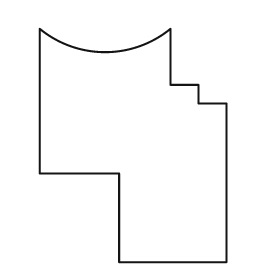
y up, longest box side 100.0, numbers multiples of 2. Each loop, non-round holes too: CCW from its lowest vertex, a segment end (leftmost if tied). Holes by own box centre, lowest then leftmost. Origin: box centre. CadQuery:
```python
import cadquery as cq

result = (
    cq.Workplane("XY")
    .moveTo(-6.0, -50.0)
    .lineTo(40.0, -50.0)
    .lineTo(40.0, 18.0)
    .lineTo(28.0, 18.0)
    .lineTo(28.0, 26.0)
    .lineTo(16.0, 26.0)
    .lineTo(16.0, 50.0)
    .threePointArc((-12.0, 40.0), (-40.0, 50.0))
    .lineTo(-40.0, -12.0)
    .lineTo(-6.0, -12.0)
    .close()
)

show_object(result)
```